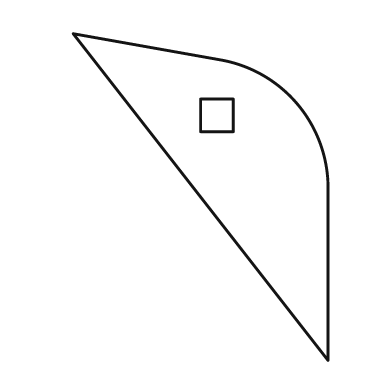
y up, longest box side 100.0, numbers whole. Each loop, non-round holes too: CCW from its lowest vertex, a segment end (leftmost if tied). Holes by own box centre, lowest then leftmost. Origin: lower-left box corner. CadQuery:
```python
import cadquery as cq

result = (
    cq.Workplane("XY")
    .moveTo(78.0, 0.0)
    .lineTo(78.0, 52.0)
    .threePointArc((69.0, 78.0), (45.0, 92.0))
    .lineTo(0.0, 100.0)
    .close()
    .moveTo(39.0, 70.0)
    .lineTo(49.0, 70.0)
    .lineTo(49.0, 80.0)
    .lineTo(39.0, 80.0)
    .close()
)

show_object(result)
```